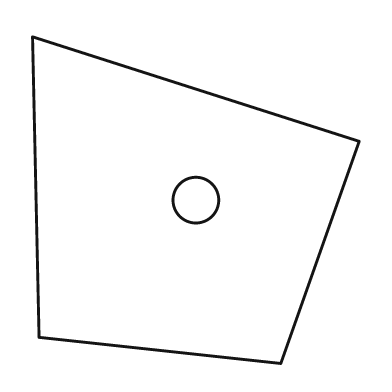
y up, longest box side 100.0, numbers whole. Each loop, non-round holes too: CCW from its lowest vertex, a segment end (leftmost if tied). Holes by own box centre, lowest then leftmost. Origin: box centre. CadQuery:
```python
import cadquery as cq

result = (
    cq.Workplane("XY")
    .moveTo(26.0, -50.0)
    .lineTo(50.0, 18.0)
    .lineTo(-50.0, 50.0)
    .lineTo(-48.0, -42.0)
    .close()
    .moveTo(0.0, 0.0)
    .circle(7.0)
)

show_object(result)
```